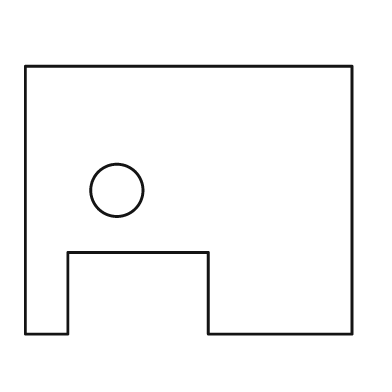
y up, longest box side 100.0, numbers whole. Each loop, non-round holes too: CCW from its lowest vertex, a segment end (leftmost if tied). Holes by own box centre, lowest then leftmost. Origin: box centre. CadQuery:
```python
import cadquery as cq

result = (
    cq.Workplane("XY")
    .moveTo(-50.0, -41.0)
    .lineTo(-37.0, -41.0)
    .lineTo(-37.0, -16.0)
    .lineTo(6.0, -16.0)
    .lineTo(6.0, -41.0)
    .lineTo(50.0, -41.0)
    .lineTo(50.0, 41.0)
    .lineTo(-50.0, 41.0)
    .close()
    .moveTo(-22.0, 3.0)
    .circle(8.0)
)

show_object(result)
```